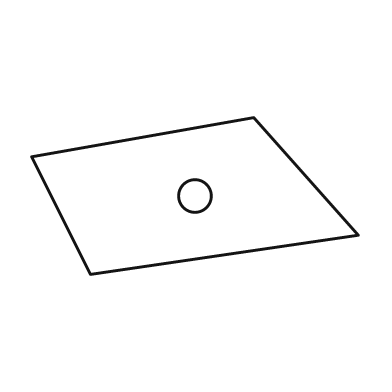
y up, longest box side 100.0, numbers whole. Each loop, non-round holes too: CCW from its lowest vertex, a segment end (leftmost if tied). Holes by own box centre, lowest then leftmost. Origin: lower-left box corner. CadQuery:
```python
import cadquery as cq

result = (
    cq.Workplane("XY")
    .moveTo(18.0, 0.0)
    .lineTo(100.0, 12.0)
    .lineTo(68.0, 48.0)
    .lineTo(0.0, 36.0)
    .close()
    .moveTo(50.0, 24.0)
    .circle(5.0)
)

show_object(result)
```